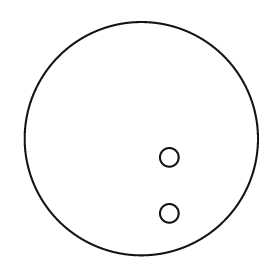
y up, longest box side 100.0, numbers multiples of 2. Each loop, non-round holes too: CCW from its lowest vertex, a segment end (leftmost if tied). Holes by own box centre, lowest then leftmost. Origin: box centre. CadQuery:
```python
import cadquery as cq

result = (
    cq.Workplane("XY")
    .moveTo(0.0, 0.0)
    .circle(50.0)
    .moveTo(12.0, -32.0)
    .circle(4.0)
    .moveTo(12.0, -8.0)
    .circle(4.0)
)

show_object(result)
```